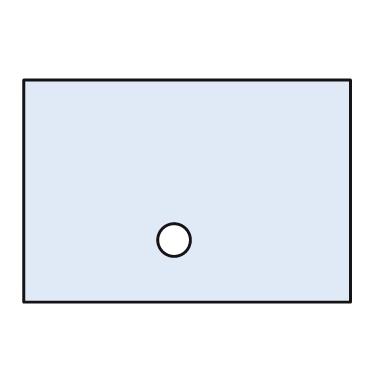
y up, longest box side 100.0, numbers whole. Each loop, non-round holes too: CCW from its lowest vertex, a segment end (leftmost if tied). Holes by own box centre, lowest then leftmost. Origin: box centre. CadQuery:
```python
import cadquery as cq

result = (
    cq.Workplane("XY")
    .moveTo(-50.0, -34.0)
    .lineTo(50.0, -34.0)
    .lineTo(50.0, 34.0)
    .lineTo(-50.0, 34.0)
    .close()
    .moveTo(-4.0, -15.0)
    .circle(5.0)
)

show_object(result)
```